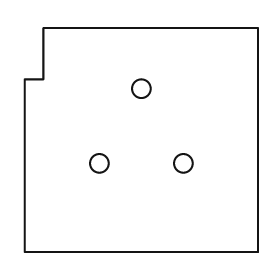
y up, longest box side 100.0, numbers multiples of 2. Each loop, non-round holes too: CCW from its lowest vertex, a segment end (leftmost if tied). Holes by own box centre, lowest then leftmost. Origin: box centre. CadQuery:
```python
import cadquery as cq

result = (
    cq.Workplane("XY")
    .moveTo(-50.0, -48.0)
    .lineTo(50.0, -48.0)
    .lineTo(50.0, 48.0)
    .lineTo(-42.0, 48.0)
    .lineTo(-42.0, 26.0)
    .lineTo(-50.0, 26.0)
    .close()
    .moveTo(-18.0, -10.0)
    .circle(4.0)
    .moveTo(18.0, -10.0)
    .circle(4.0)
    .moveTo(0.0, 22.0)
    .circle(4.0)
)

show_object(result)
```